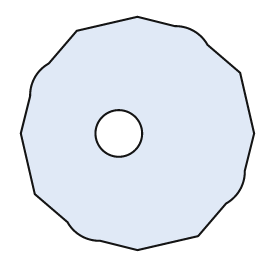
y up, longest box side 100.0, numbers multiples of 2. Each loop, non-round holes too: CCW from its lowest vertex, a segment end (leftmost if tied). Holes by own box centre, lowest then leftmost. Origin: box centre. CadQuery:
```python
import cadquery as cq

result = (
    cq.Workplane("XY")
    .moveTo(0.0, -50.0)
    .lineTo(26.0, -44.0)
    .lineTo(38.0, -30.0)
    .threePointArc((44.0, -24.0), (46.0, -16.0))
    .lineTo(50.0, 0.0)
    .lineTo(44.0, 26.0)
    .lineTo(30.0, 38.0)
    .threePointArc((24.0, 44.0), (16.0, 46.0))
    .lineTo(0.0, 50.0)
    .lineTo(-26.0, 44.0)
    .lineTo(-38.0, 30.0)
    .threePointArc((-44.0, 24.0), (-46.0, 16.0))
    .lineTo(-50.0, 0.0)
    .lineTo(-44.0, -26.0)
    .lineTo(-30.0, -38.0)
    .threePointArc((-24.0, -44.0), (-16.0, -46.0))
    .close()
    .moveTo(-8.0, 0.0)
    .circle(10.0)
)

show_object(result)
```